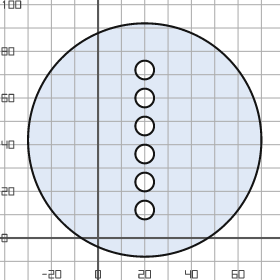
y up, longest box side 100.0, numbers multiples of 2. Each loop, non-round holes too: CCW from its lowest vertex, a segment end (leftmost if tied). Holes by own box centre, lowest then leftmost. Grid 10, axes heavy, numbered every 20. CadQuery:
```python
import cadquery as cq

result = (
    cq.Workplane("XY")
    .moveTo(20.0, 42.0)
    .circle(50.0)
    .moveTo(20.0, 12.0)
    .circle(4.0)
    .moveTo(20.0, 24.0)
    .circle(4.0)
    .moveTo(20.0, 36.0)
    .circle(4.0)
    .moveTo(20.0, 48.0)
    .circle(4.0)
    .moveTo(20.0, 60.0)
    .circle(4.0)
    .moveTo(20.0, 72.0)
    .circle(4.0)
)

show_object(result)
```